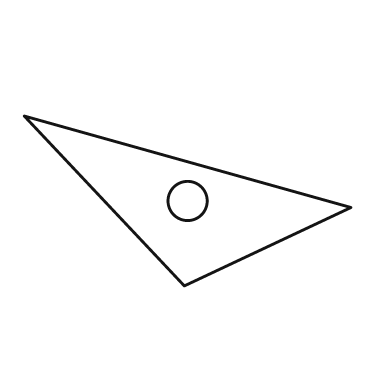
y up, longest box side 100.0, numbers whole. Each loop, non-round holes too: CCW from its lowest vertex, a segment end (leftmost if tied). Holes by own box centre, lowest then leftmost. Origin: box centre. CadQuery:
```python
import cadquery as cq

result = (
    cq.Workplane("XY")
    .moveTo(-1.0, -26.0)
    .lineTo(50.0, -2.0)
    .lineTo(-50.0, 26.0)
    .close()
    .moveTo(0.0, 0.0)
    .circle(6.0)
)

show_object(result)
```